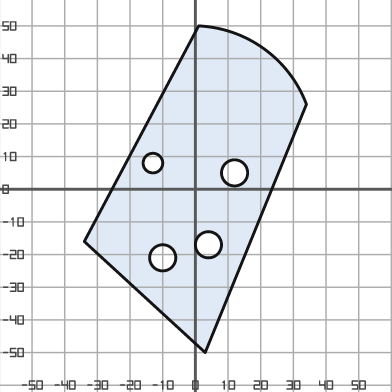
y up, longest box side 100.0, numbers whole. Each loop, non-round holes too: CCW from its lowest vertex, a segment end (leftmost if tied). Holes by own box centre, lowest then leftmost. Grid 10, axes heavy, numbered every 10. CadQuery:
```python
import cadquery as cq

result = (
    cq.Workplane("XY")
    .moveTo(3.0, -50.0)
    .lineTo(34.0, 26.0)
    .threePointArc((21.0, 43.0), (1.0, 50.0))
    .lineTo(-34.0, -16.0)
    .close()
    .moveTo(-10.0, -21.0)
    .circle(4.0)
    .moveTo(4.0, -17.0)
    .circle(4.0)
    .moveTo(12.0, 5.0)
    .circle(4.0)
    .moveTo(-13.0, 8.0)
    .circle(3.0)
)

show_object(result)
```